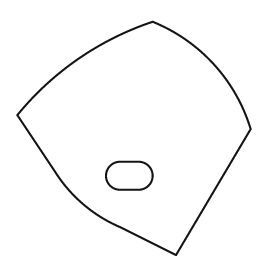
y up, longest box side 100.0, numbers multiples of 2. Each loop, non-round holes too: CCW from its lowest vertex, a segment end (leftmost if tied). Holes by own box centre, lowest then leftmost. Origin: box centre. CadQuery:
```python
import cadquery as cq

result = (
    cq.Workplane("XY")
    .moveTo(18.0, -50.0)
    .lineTo(50.0, 4.0)
    .threePointArc((34.0, 32.0), (8.0, 50.0))
    .threePointArc((-24.0, 34.0), (-50.0, 10.0))
    .lineTo(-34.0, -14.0)
    .threePointArc((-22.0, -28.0), (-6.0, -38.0))
    .close()
    .moveTo(-6.0, -22.0)
    .lineTo(2.0, -22.0)
    .threePointArc((8.0, -16.0), (2.0, -10.0))
    .lineTo(-6.0, -10.0)
    .threePointArc((-12.0, -16.0), (-6.0, -22.0))
    .close()
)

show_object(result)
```